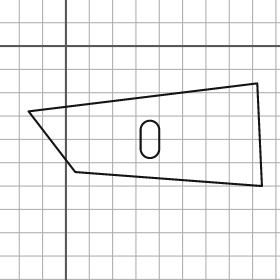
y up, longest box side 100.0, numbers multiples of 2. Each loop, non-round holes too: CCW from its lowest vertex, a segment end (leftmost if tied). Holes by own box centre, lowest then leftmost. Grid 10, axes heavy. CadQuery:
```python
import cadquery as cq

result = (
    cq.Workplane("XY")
    .moveTo(84.0, -60.0)
    .lineTo(82.0, -16.0)
    .lineTo(-16.0, -28.0)
    .lineTo(4.0, -54.0)
    .close()
    .moveTo(32.0, -44.0)
    .threePointArc((36.0, -48.0), (40.0, -44.0))
    .lineTo(40.0, -36.0)
    .threePointArc((36.0, -32.0), (32.0, -36.0))
    .close()
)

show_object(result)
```